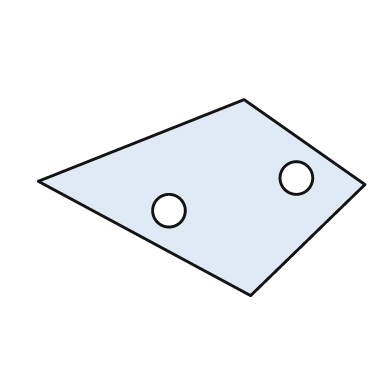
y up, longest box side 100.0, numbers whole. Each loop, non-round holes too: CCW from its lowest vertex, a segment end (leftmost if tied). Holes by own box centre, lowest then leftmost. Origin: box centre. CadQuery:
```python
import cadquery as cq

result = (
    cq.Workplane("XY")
    .moveTo(15.0, -30.0)
    .lineTo(50.0, 4.0)
    .lineTo(13.0, 30.0)
    .lineTo(-50.0, 5.0)
    .close()
    .moveTo(-10.0, -4.0)
    .circle(5.0)
    .moveTo(29.0, 6.0)
    .circle(5.0)
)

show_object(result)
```